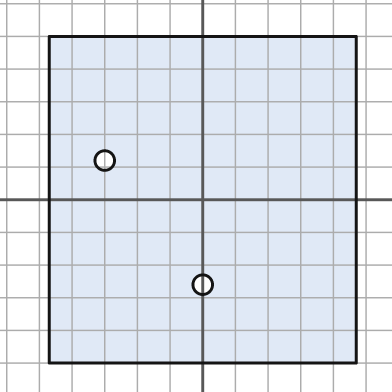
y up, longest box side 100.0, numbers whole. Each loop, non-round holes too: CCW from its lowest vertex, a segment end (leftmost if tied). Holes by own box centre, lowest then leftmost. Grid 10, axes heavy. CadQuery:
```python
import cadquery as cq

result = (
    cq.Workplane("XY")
    .moveTo(-47.0, -50.0)
    .lineTo(47.0, -50.0)
    .lineTo(47.0, 50.0)
    .lineTo(-47.0, 50.0)
    .close()
    .moveTo(0.0, -26.0)
    .circle(3.0)
    .moveTo(-30.0, 12.0)
    .circle(3.0)
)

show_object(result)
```